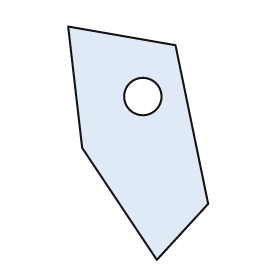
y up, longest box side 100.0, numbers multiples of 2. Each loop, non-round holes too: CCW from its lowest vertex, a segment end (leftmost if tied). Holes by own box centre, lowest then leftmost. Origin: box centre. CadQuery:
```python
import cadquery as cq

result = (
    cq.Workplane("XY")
    .moveTo(8.0, -50.0)
    .lineTo(30.0, -26.0)
    .lineTo(16.0, 42.0)
    .lineTo(-30.0, 50.0)
    .lineTo(-24.0, -2.0)
    .close()
    .moveTo(2.0, 20.0)
    .circle(8.0)
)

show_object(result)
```